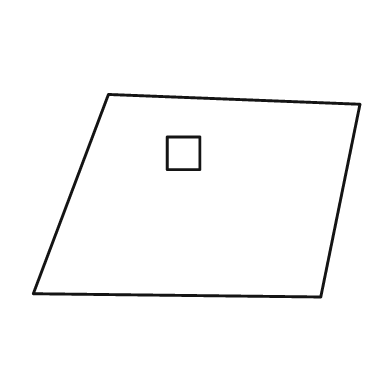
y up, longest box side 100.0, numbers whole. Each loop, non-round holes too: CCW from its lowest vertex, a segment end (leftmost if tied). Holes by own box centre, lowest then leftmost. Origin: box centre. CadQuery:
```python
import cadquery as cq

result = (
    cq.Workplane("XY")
    .moveTo(38.0, -31.0)
    .lineTo(50.0, 28.0)
    .lineTo(-27.0, 31.0)
    .lineTo(-50.0, -30.0)
    .close()
    .moveTo(-9.0, 8.0)
    .lineTo(1.0, 8.0)
    .lineTo(1.0, 18.0)
    .lineTo(-9.0, 18.0)
    .close()
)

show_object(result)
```